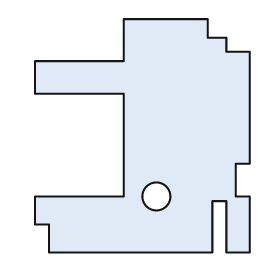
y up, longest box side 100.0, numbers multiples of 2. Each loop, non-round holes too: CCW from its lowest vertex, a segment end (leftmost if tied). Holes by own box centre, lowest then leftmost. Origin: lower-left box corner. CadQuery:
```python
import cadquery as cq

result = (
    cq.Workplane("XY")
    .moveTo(6.0, 0.0)
    .lineTo(76.0, 0.0)
    .lineTo(76.0, 22.0)
    .lineTo(82.0, 22.0)
    .lineTo(82.0, 0.0)
    .lineTo(92.0, 0.0)
    .lineTo(92.0, 24.0)
    .lineTo(86.0, 24.0)
    .lineTo(86.0, 38.0)
    .lineTo(92.0, 38.0)
    .lineTo(92.0, 86.0)
    .lineTo(82.0, 86.0)
    .lineTo(82.0, 92.0)
    .lineTo(74.0, 92.0)
    .lineTo(74.0, 100.0)
    .lineTo(38.0, 100.0)
    .lineTo(38.0, 82.0)
    .lineTo(0.0, 82.0)
    .lineTo(0.0, 68.0)
    .lineTo(38.0, 68.0)
    .lineTo(38.0, 24.0)
    .lineTo(0.0, 24.0)
    .lineTo(0.0, 12.0)
    .lineTo(6.0, 12.0)
    .close()
    .moveTo(52.0, 24.0)
    .circle(6.0)
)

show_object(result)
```